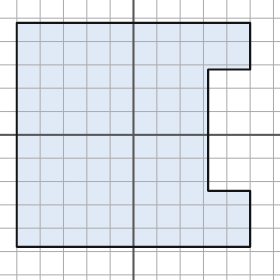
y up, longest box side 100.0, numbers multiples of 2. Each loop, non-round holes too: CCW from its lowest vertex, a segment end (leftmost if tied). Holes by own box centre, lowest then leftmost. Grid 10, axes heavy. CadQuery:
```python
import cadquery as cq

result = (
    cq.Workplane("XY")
    .moveTo(-50.0, -48.0)
    .lineTo(50.0, -48.0)
    .lineTo(50.0, -24.0)
    .lineTo(32.0, -24.0)
    .lineTo(32.0, 28.0)
    .lineTo(50.0, 28.0)
    .lineTo(50.0, 48.0)
    .lineTo(-50.0, 48.0)
    .close()
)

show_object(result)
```